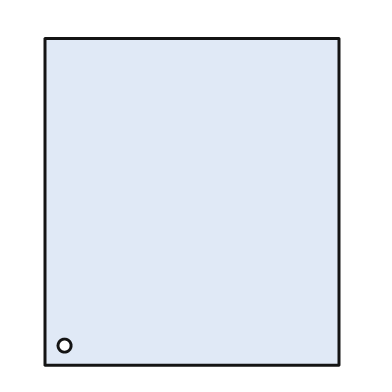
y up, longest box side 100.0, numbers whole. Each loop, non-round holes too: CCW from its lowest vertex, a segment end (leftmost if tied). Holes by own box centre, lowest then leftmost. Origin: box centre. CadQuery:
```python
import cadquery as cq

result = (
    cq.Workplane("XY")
    .moveTo(-45.0, -50.0)
    .lineTo(45.0, -50.0)
    .lineTo(45.0, 50.0)
    .lineTo(-45.0, 50.0)
    .close()
    .moveTo(-39.0, -44.0)
    .circle(2.0)
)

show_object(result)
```